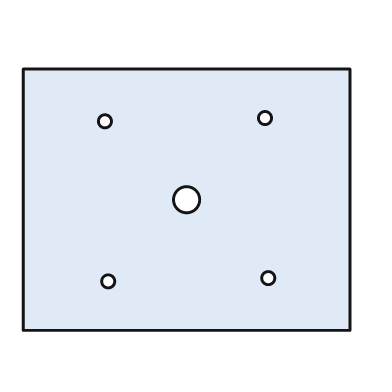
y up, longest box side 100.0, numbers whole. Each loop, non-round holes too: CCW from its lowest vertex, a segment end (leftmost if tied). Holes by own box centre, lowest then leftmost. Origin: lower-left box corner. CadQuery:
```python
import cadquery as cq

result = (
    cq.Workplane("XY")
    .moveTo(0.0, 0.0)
    .lineTo(100.0, 0.0)
    .lineTo(100.0, 80.0)
    .lineTo(0.0, 80.0)
    .close()
    .moveTo(26.0, 15.0)
    .circle(2.0)
    .moveTo(75.0, 16.0)
    .circle(2.0)
    .moveTo(50.0, 40.0)
    .circle(4.0)
    .moveTo(25.0, 64.0)
    .circle(2.0)
    .moveTo(74.0, 65.0)
    .circle(2.0)
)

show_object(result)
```